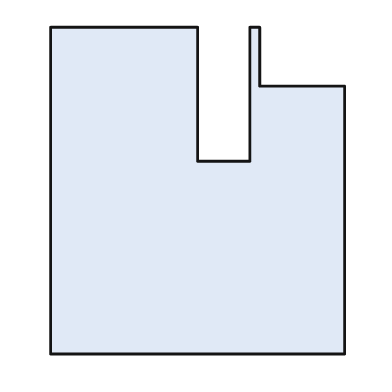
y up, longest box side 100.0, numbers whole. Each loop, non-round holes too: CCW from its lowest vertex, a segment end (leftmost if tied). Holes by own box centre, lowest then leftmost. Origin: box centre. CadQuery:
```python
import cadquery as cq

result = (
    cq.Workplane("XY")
    .moveTo(-45.0, -50.0)
    .lineTo(45.0, -50.0)
    .lineTo(45.0, 32.0)
    .lineTo(19.0, 32.0)
    .lineTo(19.0, 50.0)
    .lineTo(16.0, 50.0)
    .lineTo(16.0, 9.0)
    .lineTo(0.0, 9.0)
    .lineTo(0.0, 50.0)
    .lineTo(-45.0, 50.0)
    .close()
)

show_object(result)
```